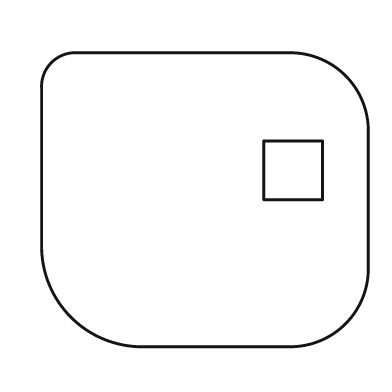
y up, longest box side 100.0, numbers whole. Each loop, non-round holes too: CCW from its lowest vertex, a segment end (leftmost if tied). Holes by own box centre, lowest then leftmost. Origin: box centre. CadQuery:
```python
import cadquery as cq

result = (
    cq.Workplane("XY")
    .moveTo(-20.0, -45.0)
    .lineTo(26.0, -45.0)
    .threePointArc((43.0, -38.0), (50.0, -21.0))
    .lineTo(50.0, 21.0)
    .threePointArc((43.0, 38.0), (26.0, 45.0))
    .lineTo(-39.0, 45.0)
    .threePointArc((-47.0, 42.0), (-50.0, 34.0))
    .lineTo(-50.0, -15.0)
    .threePointArc((-41.0, -36.0), (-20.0, -45.0))
    .close()
    .moveTo(18.0, 0.0)
    .lineTo(36.0, 0.0)
    .lineTo(36.0, 18.0)
    .lineTo(18.0, 18.0)
    .close()
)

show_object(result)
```